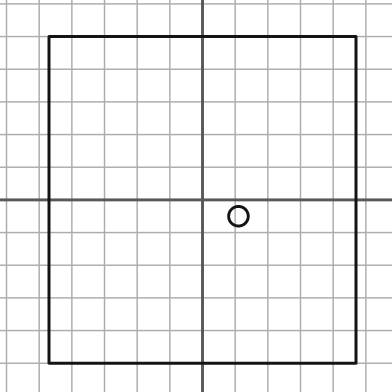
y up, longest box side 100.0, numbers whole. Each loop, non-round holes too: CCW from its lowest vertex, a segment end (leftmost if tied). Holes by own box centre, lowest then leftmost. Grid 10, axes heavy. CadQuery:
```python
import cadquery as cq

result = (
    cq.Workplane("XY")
    .moveTo(-47.0, -50.0)
    .lineTo(47.0, -50.0)
    .lineTo(47.0, 50.0)
    .lineTo(-47.0, 50.0)
    .close()
    .moveTo(11.0, -5.0)
    .circle(3.0)
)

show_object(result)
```